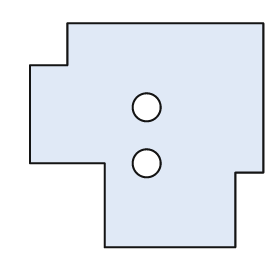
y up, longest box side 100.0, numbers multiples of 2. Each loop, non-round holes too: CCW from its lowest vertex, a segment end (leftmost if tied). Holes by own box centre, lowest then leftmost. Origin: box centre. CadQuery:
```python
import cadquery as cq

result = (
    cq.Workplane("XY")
    .moveTo(-18.0, -48.0)
    .lineTo(38.0, -48.0)
    .lineTo(38.0, -16.0)
    .lineTo(50.0, -16.0)
    .lineTo(50.0, 48.0)
    .lineTo(-34.0, 48.0)
    .lineTo(-34.0, 30.0)
    .lineTo(-50.0, 30.0)
    .lineTo(-50.0, -12.0)
    .lineTo(-18.0, -12.0)
    .close()
    .moveTo(0.0, -12.0)
    .circle(6.0)
    .moveTo(0.0, 12.0)
    .circle(6.0)
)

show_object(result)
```